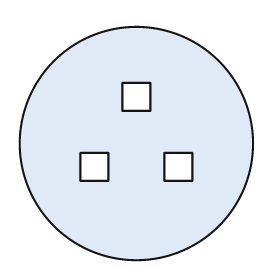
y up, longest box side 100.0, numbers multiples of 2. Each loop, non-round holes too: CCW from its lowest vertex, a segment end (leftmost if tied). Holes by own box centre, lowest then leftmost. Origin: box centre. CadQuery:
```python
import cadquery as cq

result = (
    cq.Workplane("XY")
    .moveTo(0.0, 0.0)
    .circle(50.0)
    .moveTo(-24.0, -16.0)
    .lineTo(-12.0, -16.0)
    .lineTo(-12.0, -4.0)
    .lineTo(-24.0, -4.0)
    .close()
    .moveTo(12.0, -16.0)
    .lineTo(24.0, -16.0)
    .lineTo(24.0, -4.0)
    .lineTo(12.0, -4.0)
    .close()
    .moveTo(-6.0, 14.0)
    .lineTo(6.0, 14.0)
    .lineTo(6.0, 26.0)
    .lineTo(-6.0, 26.0)
    .close()
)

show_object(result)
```